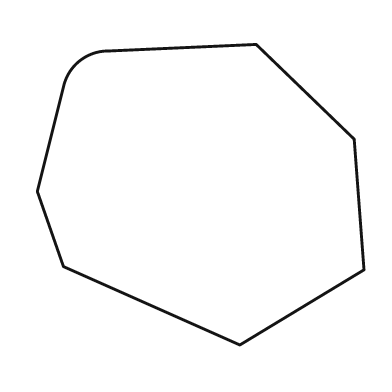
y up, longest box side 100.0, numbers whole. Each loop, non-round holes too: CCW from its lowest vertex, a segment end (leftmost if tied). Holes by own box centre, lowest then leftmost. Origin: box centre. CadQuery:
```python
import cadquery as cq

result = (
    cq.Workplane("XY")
    .moveTo(12.0, -46.0)
    .lineTo(50.0, -23.0)
    .lineTo(47.0, 17.0)
    .lineTo(17.0, 46.0)
    .lineTo(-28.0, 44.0)
    .threePointArc((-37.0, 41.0), (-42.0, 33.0))
    .lineTo(-50.0, 1.0)
    .lineTo(-42.0, -22.0)
    .close()
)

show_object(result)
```